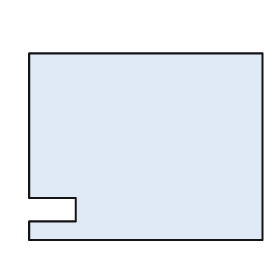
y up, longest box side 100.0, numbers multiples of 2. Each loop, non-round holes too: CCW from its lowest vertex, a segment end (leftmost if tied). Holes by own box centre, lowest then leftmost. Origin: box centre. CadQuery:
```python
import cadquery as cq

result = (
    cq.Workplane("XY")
    .moveTo(-50.0, -40.0)
    .lineTo(50.0, -40.0)
    .lineTo(50.0, 40.0)
    .lineTo(-50.0, 40.0)
    .lineTo(-50.0, -22.0)
    .lineTo(-30.0, -22.0)
    .lineTo(-30.0, -32.0)
    .lineTo(-50.0, -32.0)
    .close()
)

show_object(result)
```